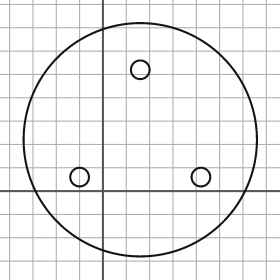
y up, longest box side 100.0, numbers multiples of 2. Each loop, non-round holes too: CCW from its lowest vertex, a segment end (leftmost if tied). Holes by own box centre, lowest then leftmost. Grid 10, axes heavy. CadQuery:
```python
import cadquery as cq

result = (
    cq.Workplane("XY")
    .moveTo(16.0, 22.0)
    .circle(50.0)
    .moveTo(-10.0, 6.0)
    .circle(4.0)
    .moveTo(42.0, 6.0)
    .circle(4.0)
    .moveTo(16.0, 52.0)
    .circle(4.0)
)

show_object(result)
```